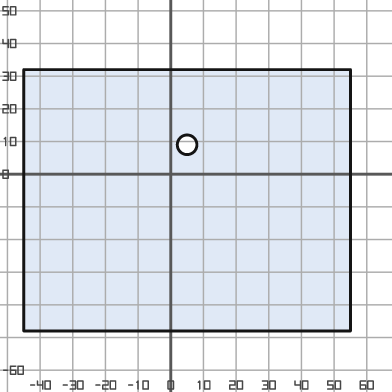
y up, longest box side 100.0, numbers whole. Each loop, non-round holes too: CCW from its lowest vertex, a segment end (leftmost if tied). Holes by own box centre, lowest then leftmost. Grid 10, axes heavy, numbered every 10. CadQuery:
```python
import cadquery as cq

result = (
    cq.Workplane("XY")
    .moveTo(-45.0, -48.0)
    .lineTo(55.0, -48.0)
    .lineTo(55.0, 32.0)
    .lineTo(-45.0, 32.0)
    .close()
    .moveTo(5.0, 9.0)
    .circle(3.0)
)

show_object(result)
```